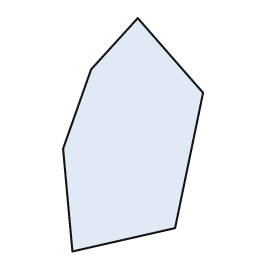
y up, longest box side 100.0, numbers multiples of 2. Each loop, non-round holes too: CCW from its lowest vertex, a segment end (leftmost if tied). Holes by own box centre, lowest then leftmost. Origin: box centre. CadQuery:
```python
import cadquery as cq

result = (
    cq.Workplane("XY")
    .moveTo(-26.0, -50.0)
    .lineTo(18.0, -40.0)
    .lineTo(30.0, 18.0)
    .lineTo(2.0, 50.0)
    .lineTo(-18.0, 28.0)
    .lineTo(-30.0, -6.0)
    .close()
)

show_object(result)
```